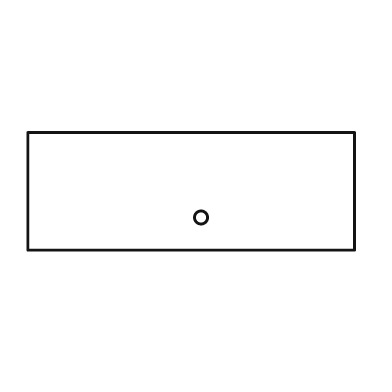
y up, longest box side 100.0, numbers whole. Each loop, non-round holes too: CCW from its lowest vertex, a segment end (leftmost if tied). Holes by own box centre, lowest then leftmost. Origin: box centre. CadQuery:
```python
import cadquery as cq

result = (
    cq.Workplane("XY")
    .moveTo(-50.0, -18.0)
    .lineTo(50.0, -18.0)
    .lineTo(50.0, 18.0)
    .lineTo(-50.0, 18.0)
    .close()
    .moveTo(3.0, -8.0)
    .circle(2.0)
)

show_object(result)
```